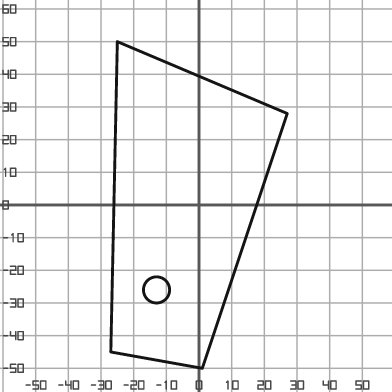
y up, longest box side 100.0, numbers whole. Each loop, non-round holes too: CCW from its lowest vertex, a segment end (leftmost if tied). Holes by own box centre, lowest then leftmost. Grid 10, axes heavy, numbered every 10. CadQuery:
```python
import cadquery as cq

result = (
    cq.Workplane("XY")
    .moveTo(1.0, -50.0)
    .lineTo(27.0, 28.0)
    .lineTo(-25.0, 50.0)
    .lineTo(-27.0, -45.0)
    .close()
    .moveTo(-13.0, -26.0)
    .circle(4.0)
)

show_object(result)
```